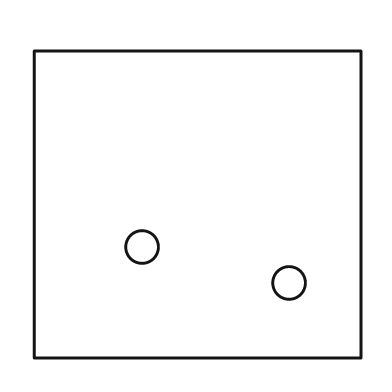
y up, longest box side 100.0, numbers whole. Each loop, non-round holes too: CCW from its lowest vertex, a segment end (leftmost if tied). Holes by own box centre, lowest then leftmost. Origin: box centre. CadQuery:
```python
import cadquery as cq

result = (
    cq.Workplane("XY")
    .moveTo(-50.0, -47.0)
    .lineTo(50.0, -47.0)
    .lineTo(50.0, 47.0)
    .lineTo(-50.0, 47.0)
    .close()
    .moveTo(28.0, -24.0)
    .circle(5.0)
    .moveTo(-17.0, -13.0)
    .circle(5.0)
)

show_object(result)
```